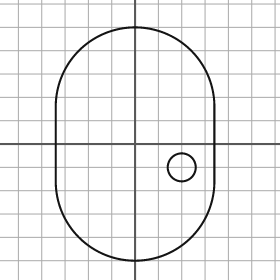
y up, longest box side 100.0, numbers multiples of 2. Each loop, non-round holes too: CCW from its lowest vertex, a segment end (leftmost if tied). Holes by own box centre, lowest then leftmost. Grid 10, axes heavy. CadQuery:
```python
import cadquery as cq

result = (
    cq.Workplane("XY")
    .moveTo(-34.0, -16.0)
    .threePointArc((0.0, -50.0), (34.0, -16.0))
    .lineTo(34.0, 16.0)
    .threePointArc((0.0, 50.0), (-34.0, 16.0))
    .close()
    .moveTo(20.0, -10.0)
    .circle(6.0)
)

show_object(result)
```